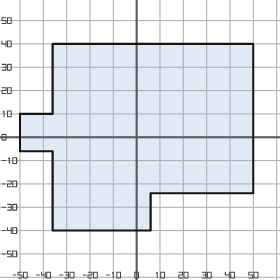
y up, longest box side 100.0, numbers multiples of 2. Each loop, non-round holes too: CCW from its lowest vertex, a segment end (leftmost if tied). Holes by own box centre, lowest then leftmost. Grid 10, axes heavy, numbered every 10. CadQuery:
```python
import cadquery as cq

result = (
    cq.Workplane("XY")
    .moveTo(-36.0, -40.0)
    .lineTo(6.0, -40.0)
    .lineTo(6.0, -24.0)
    .lineTo(50.0, -24.0)
    .lineTo(50.0, 40.0)
    .lineTo(-36.0, 40.0)
    .lineTo(-36.0, 10.0)
    .lineTo(-50.0, 10.0)
    .lineTo(-50.0, -6.0)
    .lineTo(-36.0, -6.0)
    .close()
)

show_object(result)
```